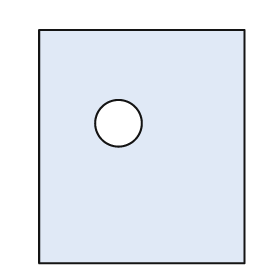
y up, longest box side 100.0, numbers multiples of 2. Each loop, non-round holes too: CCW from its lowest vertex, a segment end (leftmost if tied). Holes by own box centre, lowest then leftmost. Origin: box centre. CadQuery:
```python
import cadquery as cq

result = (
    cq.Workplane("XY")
    .moveTo(-44.0, -50.0)
    .lineTo(44.0, -50.0)
    .lineTo(44.0, 50.0)
    .lineTo(-44.0, 50.0)
    .close()
    .moveTo(-10.0, 10.0)
    .circle(10.0)
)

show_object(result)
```